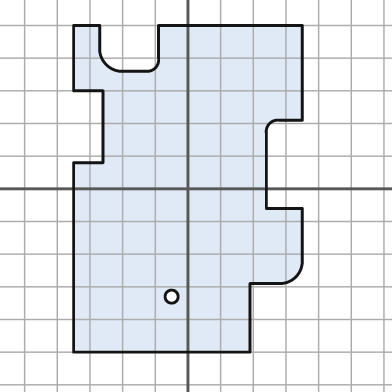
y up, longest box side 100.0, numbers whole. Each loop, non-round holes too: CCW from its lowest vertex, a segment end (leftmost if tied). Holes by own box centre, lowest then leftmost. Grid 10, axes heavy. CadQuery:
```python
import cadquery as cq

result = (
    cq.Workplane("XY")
    .moveTo(-35.0, -50.0)
    .lineTo(19.0, -50.0)
    .lineTo(19.0, -29.0)
    .lineTo(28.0, -29.0)
    .threePointArc((33.0, -27.0), (35.0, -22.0))
    .lineTo(35.0, -6.0)
    .lineTo(24.0, -6.0)
    .lineTo(24.0, 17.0)
    .threePointArc((25.0, 20.0), (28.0, 21.0))
    .lineTo(35.0, 21.0)
    .lineTo(35.0, 50.0)
    .lineTo(-9.0, 50.0)
    .lineTo(-9.0, 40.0)
    .threePointArc((-10.0, 37.0), (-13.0, 36.0))
    .lineTo(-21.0, 36.0)
    .threePointArc((-25.0, 38.0), (-27.0, 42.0))
    .lineTo(-27.0, 50.0)
    .lineTo(-35.0, 50.0)
    .lineTo(-35.0, 30.0)
    .lineTo(-26.0, 30.0)
    .lineTo(-26.0, 8.0)
    .lineTo(-35.0, 8.0)
    .close()
    .moveTo(-5.0, -33.0)
    .circle(2.0)
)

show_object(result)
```